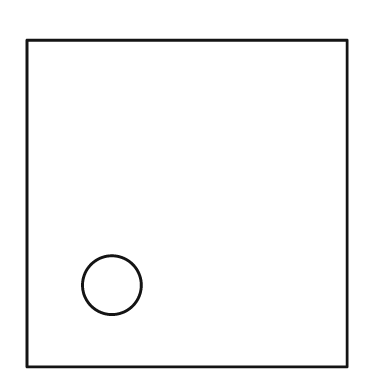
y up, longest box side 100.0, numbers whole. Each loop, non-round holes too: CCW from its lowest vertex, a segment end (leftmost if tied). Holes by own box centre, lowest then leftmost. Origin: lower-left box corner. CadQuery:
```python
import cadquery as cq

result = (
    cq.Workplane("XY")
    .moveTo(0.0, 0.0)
    .lineTo(98.0, 0.0)
    .lineTo(98.0, 100.0)
    .lineTo(0.0, 100.0)
    .close()
    .moveTo(26.0, 25.0)
    .circle(9.0)
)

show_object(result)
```